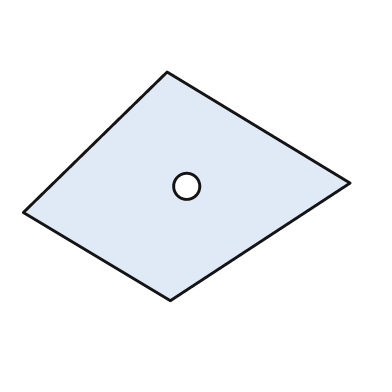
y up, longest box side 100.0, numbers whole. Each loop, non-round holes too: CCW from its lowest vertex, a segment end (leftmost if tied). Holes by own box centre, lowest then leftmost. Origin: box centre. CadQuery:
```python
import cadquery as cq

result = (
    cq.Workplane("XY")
    .moveTo(-5.0, -35.0)
    .lineTo(50.0, 1.0)
    .lineTo(-6.0, 35.0)
    .lineTo(-50.0, -8.0)
    .close()
    .moveTo(0.0, 0.0)
    .circle(4.0)
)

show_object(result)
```